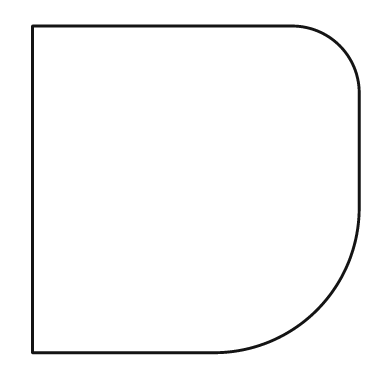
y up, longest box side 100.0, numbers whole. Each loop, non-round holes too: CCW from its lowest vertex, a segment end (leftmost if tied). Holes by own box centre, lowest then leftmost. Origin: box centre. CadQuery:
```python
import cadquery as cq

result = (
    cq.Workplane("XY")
    .moveTo(-50.0, -50.0)
    .lineTo(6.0, -50.0)
    .threePointArc((37.0, -37.0), (50.0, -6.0))
    .lineTo(50.0, 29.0)
    .threePointArc((44.0, 44.0), (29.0, 50.0))
    .lineTo(-50.0, 50.0)
    .close()
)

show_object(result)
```